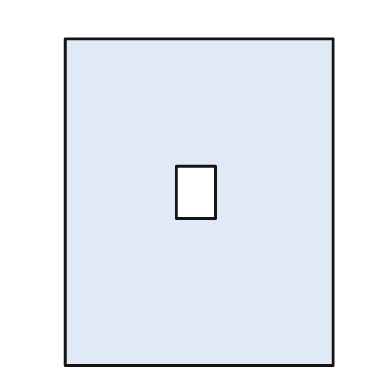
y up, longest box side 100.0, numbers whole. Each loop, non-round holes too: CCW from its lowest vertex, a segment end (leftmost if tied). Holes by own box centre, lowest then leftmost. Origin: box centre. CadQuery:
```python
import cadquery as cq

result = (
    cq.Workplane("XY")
    .moveTo(-41.0, -50.0)
    .lineTo(41.0, -50.0)
    .lineTo(41.0, 50.0)
    .lineTo(-41.0, 50.0)
    .close()
    .moveTo(-7.0, -5.0)
    .lineTo(5.0, -5.0)
    .lineTo(5.0, 11.0)
    .lineTo(-7.0, 11.0)
    .close()
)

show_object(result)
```